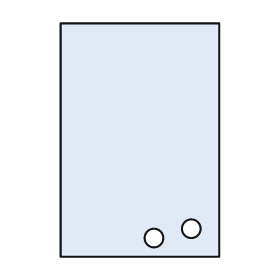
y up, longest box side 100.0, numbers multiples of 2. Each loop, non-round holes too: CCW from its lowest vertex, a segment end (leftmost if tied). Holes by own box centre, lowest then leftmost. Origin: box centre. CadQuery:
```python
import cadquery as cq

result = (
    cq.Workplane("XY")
    .moveTo(-34.0, -50.0)
    .lineTo(34.0, -50.0)
    .lineTo(34.0, 50.0)
    .lineTo(-34.0, 50.0)
    .close()
    .moveTo(6.0, -42.0)
    .circle(4.0)
    .moveTo(22.0, -38.0)
    .circle(4.0)
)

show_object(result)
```